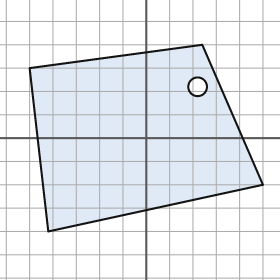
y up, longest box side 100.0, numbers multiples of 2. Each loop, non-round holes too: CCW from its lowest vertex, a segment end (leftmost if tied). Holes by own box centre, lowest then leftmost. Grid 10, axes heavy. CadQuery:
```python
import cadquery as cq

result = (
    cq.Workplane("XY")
    .moveTo(-42.0, -40.0)
    .lineTo(50.0, -20.0)
    .lineTo(24.0, 40.0)
    .lineTo(-50.0, 30.0)
    .close()
    .moveTo(22.0, 22.0)
    .circle(4.0)
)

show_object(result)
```